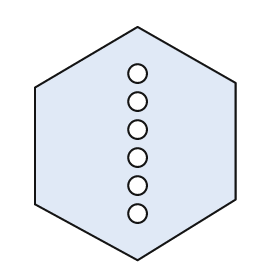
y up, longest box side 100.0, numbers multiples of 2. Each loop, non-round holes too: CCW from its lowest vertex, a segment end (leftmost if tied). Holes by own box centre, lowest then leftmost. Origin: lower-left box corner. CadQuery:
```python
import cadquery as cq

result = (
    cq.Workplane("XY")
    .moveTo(44.0, 0.0)
    .lineTo(86.0, 26.0)
    .lineTo(86.0, 76.0)
    .lineTo(44.0, 100.0)
    .lineTo(0.0, 74.0)
    .lineTo(0.0, 24.0)
    .close()
    .moveTo(44.0, 20.0)
    .circle(4.0)
    .moveTo(44.0, 32.0)
    .circle(4.0)
    .moveTo(44.0, 44.0)
    .circle(4.0)
    .moveTo(44.0, 56.0)
    .circle(4.0)
    .moveTo(44.0, 68.0)
    .circle(4.0)
    .moveTo(44.0, 80.0)
    .circle(4.0)
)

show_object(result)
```